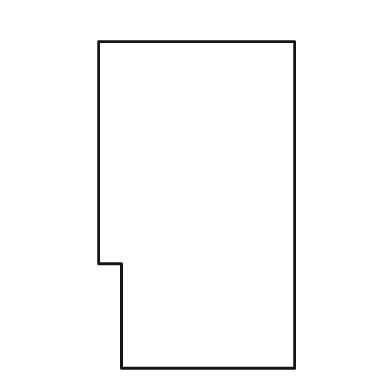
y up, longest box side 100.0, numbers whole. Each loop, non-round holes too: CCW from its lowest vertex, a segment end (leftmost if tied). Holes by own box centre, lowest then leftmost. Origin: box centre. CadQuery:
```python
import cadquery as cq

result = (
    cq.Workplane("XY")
    .moveTo(-23.0, -50.0)
    .lineTo(30.0, -50.0)
    .lineTo(30.0, 50.0)
    .lineTo(-30.0, 50.0)
    .lineTo(-30.0, -18.0)
    .lineTo(-23.0, -18.0)
    .close()
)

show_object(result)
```